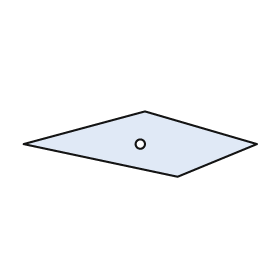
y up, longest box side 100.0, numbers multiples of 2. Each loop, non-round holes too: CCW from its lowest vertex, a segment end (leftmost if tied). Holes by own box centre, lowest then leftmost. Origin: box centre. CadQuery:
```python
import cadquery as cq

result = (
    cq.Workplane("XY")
    .moveTo(16.0, -14.0)
    .lineTo(50.0, 0.0)
    .lineTo(2.0, 14.0)
    .lineTo(-50.0, 0.0)
    .close()
    .moveTo(0.0, 0.0)
    .circle(2.0)
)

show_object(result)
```